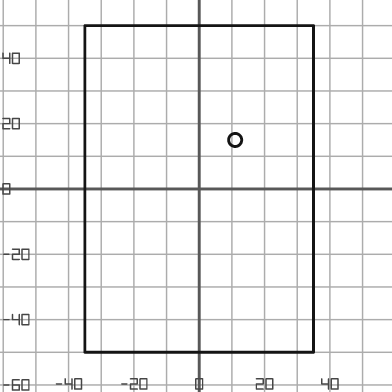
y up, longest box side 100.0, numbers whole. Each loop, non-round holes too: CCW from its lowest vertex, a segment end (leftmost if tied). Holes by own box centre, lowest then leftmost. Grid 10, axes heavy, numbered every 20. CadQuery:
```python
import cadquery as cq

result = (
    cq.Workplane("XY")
    .moveTo(-35.0, -50.0)
    .lineTo(35.0, -50.0)
    .lineTo(35.0, 50.0)
    .lineTo(-35.0, 50.0)
    .close()
    .moveTo(11.0, 15.0)
    .circle(2.0)
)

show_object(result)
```